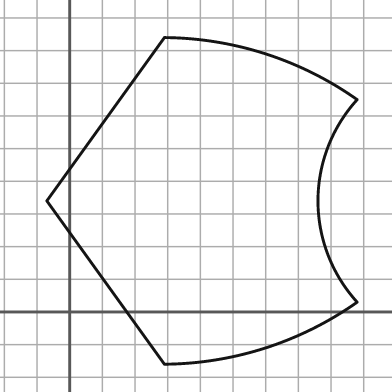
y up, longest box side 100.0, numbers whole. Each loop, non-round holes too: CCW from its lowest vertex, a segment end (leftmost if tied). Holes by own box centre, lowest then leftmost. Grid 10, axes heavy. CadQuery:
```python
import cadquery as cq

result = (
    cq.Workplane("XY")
    .moveTo(29.0, -16.0)
    .threePointArc((60.0, -11.0), (88.0, 3.0))
    .threePointArc((76.0, 34.0), (88.0, 65.0))
    .threePointArc((60.0, 79.0), (29.0, 84.0))
    .lineTo(-7.0, 34.0)
    .close()
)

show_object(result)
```